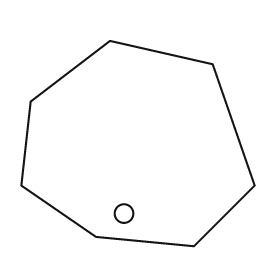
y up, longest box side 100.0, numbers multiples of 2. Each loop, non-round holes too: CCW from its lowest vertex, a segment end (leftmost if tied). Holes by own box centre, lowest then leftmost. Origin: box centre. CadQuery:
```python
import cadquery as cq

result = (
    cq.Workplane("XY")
    .moveTo(24.0, -44.0)
    .lineTo(50.0, -18.0)
    .lineTo(32.0, 34.0)
    .lineTo(-12.0, 44.0)
    .lineTo(-46.0, 18.0)
    .lineTo(-50.0, -18.0)
    .lineTo(-18.0, -40.0)
    .close()
    .moveTo(-6.0, -30.0)
    .circle(4.0)
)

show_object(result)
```